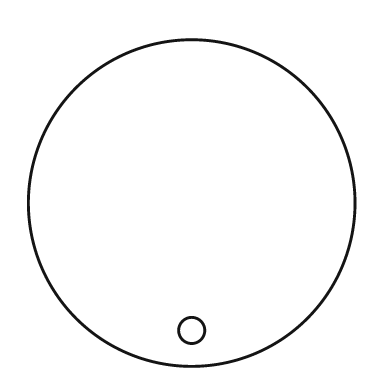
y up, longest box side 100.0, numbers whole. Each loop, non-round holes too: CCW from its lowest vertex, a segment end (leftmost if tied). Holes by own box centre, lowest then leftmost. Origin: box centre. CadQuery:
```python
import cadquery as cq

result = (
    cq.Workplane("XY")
    .moveTo(0.0, 0.0)
    .circle(50.0)
    .moveTo(0.0, -39.0)
    .circle(4.0)
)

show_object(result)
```